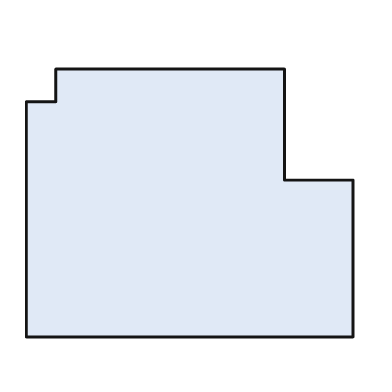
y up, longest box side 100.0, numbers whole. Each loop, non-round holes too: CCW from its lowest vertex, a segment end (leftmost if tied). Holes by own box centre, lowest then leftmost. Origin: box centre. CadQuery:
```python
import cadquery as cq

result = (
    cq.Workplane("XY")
    .moveTo(-50.0, -41.0)
    .lineTo(50.0, -41.0)
    .lineTo(50.0, 7.0)
    .lineTo(29.0, 7.0)
    .lineTo(29.0, 41.0)
    .lineTo(-41.0, 41.0)
    .lineTo(-41.0, 31.0)
    .lineTo(-50.0, 31.0)
    .close()
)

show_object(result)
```